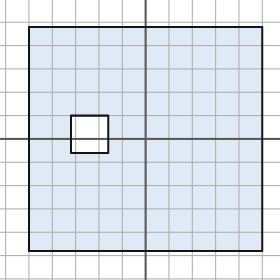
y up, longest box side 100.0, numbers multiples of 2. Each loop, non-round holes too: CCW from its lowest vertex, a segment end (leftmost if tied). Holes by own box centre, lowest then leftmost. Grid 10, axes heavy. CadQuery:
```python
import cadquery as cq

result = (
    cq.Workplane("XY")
    .moveTo(-50.0, -48.0)
    .lineTo(50.0, -48.0)
    .lineTo(50.0, 48.0)
    .lineTo(-50.0, 48.0)
    .close()
    .moveTo(-32.0, -6.0)
    .lineTo(-16.0, -6.0)
    .lineTo(-16.0, 10.0)
    .lineTo(-32.0, 10.0)
    .close()
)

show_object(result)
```